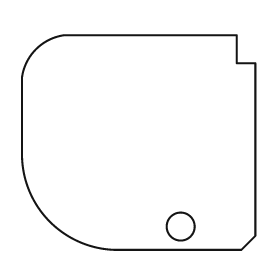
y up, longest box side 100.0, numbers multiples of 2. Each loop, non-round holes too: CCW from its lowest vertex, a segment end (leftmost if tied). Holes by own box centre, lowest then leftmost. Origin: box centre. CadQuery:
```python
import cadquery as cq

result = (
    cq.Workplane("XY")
    .moveTo(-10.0, -46.0)
    .lineTo(44.0, -46.0)
    .lineTo(50.0, -40.0)
    .lineTo(50.0, 34.0)
    .lineTo(42.0, 34.0)
    .lineTo(42.0, 46.0)
    .lineTo(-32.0, 46.0)
    .threePointArc((-44.0, 40.0), (-50.0, 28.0))
    .lineTo(-50.0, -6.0)
    .threePointArc((-38.0, -34.0), (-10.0, -46.0))
    .close()
    .moveTo(18.0, -36.0)
    .circle(6.0)
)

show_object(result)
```